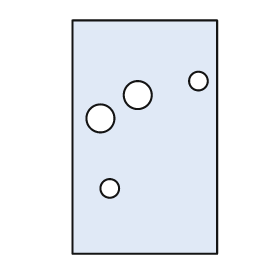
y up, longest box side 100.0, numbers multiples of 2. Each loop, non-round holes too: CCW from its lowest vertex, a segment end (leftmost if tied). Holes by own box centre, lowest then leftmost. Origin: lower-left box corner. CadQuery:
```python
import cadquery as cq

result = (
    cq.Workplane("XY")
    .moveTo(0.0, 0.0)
    .lineTo(62.0, 0.0)
    .lineTo(62.0, 100.0)
    .lineTo(0.0, 100.0)
    .close()
    .moveTo(16.0, 28.0)
    .circle(4.0)
    .moveTo(12.0, 58.0)
    .circle(6.0)
    .moveTo(28.0, 68.0)
    .circle(6.0)
    .moveTo(54.0, 74.0)
    .circle(4.0)
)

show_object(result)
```